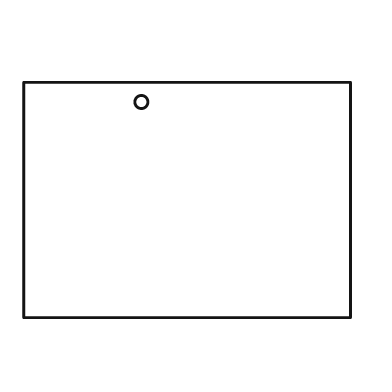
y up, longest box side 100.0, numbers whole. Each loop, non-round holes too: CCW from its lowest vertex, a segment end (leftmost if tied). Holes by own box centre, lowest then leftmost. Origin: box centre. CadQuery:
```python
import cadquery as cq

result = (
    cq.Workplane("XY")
    .moveTo(-50.0, -36.0)
    .lineTo(50.0, -36.0)
    .lineTo(50.0, 36.0)
    .lineTo(-50.0, 36.0)
    .close()
    .moveTo(-14.0, 30.0)
    .circle(2.0)
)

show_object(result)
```